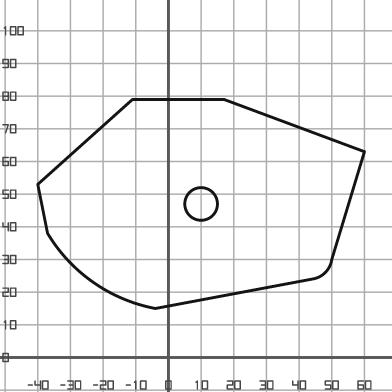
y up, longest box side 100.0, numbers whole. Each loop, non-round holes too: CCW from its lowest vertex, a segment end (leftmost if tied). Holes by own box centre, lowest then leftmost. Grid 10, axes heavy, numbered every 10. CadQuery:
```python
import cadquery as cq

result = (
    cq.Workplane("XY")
    .moveTo(-4.0, 15.0)
    .lineTo(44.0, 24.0)
    .threePointArc((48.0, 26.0), (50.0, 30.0))
    .lineTo(60.0, 63.0)
    .lineTo(17.0, 79.0)
    .lineTo(-11.0, 79.0)
    .lineTo(-40.0, 53.0)
    .lineTo(-37.0, 38.0)
    .threePointArc((-23.0, 23.0), (-4.0, 15.0))
    .close()
    .moveTo(10.0, 47.0)
    .circle(5.0)
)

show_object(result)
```